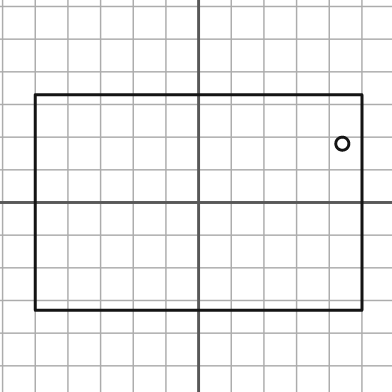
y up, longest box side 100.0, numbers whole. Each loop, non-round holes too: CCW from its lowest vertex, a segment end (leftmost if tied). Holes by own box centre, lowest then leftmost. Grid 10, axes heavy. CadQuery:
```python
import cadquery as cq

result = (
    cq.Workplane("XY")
    .moveTo(-50.0, -33.0)
    .lineTo(50.0, -33.0)
    .lineTo(50.0, 33.0)
    .lineTo(-50.0, 33.0)
    .close()
    .moveTo(44.0, 18.0)
    .circle(2.0)
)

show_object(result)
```